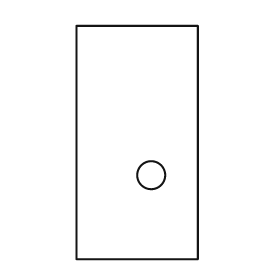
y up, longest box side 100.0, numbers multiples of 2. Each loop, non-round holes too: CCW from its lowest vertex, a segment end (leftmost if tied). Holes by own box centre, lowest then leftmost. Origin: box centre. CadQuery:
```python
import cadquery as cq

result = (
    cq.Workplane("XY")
    .moveTo(-26.0, -50.0)
    .lineTo(26.0, -50.0)
    .lineTo(26.0, 50.0)
    .lineTo(-26.0, 50.0)
    .close()
    .moveTo(6.0, -14.0)
    .circle(6.0)
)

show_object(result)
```